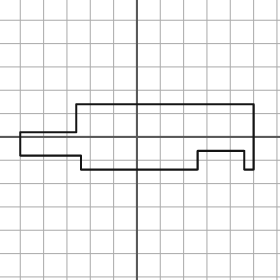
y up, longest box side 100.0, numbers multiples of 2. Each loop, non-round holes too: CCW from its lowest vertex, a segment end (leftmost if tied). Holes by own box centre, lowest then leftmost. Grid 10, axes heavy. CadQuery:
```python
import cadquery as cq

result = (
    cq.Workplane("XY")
    .moveTo(-24.0, -14.0)
    .lineTo(26.0, -14.0)
    .lineTo(26.0, -6.0)
    .lineTo(46.0, -6.0)
    .lineTo(46.0, -14.0)
    .lineTo(50.0, -14.0)
    .lineTo(50.0, 14.0)
    .lineTo(-26.0, 14.0)
    .lineTo(-26.0, 2.0)
    .lineTo(-50.0, 2.0)
    .lineTo(-50.0, -8.0)
    .lineTo(-24.0, -8.0)
    .close()
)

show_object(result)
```